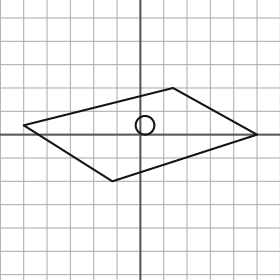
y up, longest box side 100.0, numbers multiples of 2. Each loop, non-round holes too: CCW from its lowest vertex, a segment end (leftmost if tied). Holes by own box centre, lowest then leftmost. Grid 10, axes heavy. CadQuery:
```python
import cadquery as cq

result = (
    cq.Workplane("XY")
    .moveTo(-12.0, -20.0)
    .lineTo(50.0, 0.0)
    .lineTo(14.0, 20.0)
    .lineTo(-50.0, 4.0)
    .close()
    .moveTo(2.0, 4.0)
    .circle(4.0)
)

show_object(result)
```